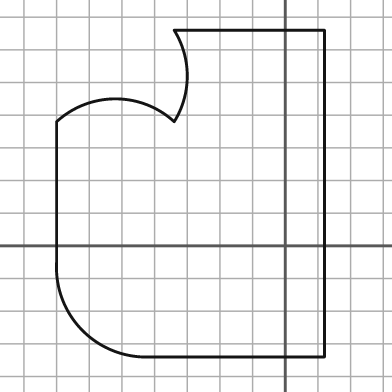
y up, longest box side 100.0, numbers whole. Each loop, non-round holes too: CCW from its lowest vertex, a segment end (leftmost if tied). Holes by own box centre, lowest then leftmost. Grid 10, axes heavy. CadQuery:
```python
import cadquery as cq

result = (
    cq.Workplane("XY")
    .moveTo(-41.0, -34.0)
    .lineTo(12.0, -34.0)
    .lineTo(12.0, 66.0)
    .lineTo(-34.0, 66.0)
    .threePointArc((-30.0, 52.0), (-34.0, 38.0))
    .threePointArc((-52.0, 45.0), (-70.0, 38.0))
    .lineTo(-70.0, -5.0)
    .threePointArc((-62.0, -26.0), (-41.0, -34.0))
    .close()
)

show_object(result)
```